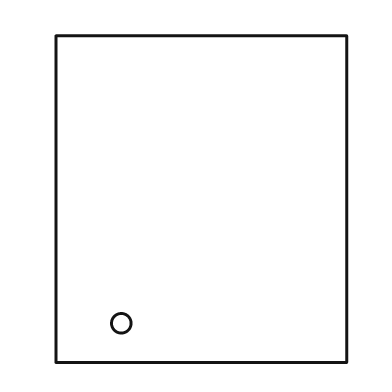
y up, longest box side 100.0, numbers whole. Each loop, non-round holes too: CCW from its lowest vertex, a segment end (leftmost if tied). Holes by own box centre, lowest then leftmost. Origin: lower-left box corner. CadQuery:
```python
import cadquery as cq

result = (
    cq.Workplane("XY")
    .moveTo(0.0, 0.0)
    .lineTo(89.0, 0.0)
    .lineTo(89.0, 100.0)
    .lineTo(0.0, 100.0)
    .close()
    .moveTo(20.0, 12.0)
    .circle(3.0)
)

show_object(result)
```